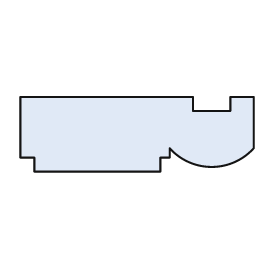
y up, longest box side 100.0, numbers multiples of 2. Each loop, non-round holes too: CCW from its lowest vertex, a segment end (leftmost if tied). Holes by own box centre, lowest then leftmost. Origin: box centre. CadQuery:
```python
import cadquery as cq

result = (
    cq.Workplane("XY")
    .moveTo(-44.0, -16.0)
    .lineTo(10.0, -16.0)
    .lineTo(10.0, -10.0)
    .lineTo(14.0, -10.0)
    .lineTo(14.0, -6.0)
    .threePointArc((32.0, -14.0), (50.0, -6.0))
    .lineTo(50.0, 16.0)
    .lineTo(40.0, 16.0)
    .lineTo(40.0, 10.0)
    .lineTo(24.0, 10.0)
    .lineTo(24.0, 16.0)
    .lineTo(-50.0, 16.0)
    .lineTo(-50.0, -10.0)
    .lineTo(-44.0, -10.0)
    .close()
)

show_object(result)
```